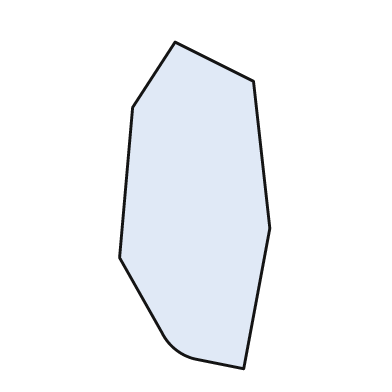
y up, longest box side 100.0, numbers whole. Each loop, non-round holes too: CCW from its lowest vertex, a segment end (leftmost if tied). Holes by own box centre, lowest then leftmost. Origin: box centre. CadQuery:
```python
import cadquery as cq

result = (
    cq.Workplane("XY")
    .moveTo(15.0, -50.0)
    .lineTo(23.0, -7.0)
    .lineTo(18.0, 38.0)
    .lineTo(-6.0, 50.0)
    .lineTo(-19.0, 30.0)
    .lineTo(-23.0, -16.0)
    .lineTo(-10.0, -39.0)
    .threePointArc((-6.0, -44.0), (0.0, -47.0))
    .close()
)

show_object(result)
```